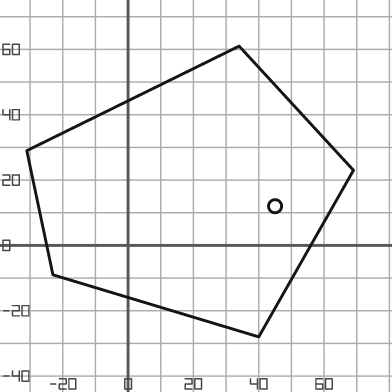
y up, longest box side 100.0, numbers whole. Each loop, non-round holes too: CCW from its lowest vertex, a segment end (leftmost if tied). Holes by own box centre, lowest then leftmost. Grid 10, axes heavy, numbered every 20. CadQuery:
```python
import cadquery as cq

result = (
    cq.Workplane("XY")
    .moveTo(40.0, -28.0)
    .lineTo(69.0, 23.0)
    .lineTo(34.0, 61.0)
    .lineTo(-31.0, 29.0)
    .lineTo(-23.0, -9.0)
    .close()
    .moveTo(45.0, 12.0)
    .circle(2.0)
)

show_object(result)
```